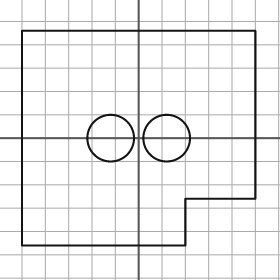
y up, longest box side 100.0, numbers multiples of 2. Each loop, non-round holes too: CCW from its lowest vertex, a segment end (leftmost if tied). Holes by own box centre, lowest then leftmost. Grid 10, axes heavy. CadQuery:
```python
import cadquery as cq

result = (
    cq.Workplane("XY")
    .moveTo(-50.0, -46.0)
    .lineTo(20.0, -46.0)
    .lineTo(20.0, -26.0)
    .lineTo(50.0, -26.0)
    .lineTo(50.0, 46.0)
    .lineTo(-50.0, 46.0)
    .close()
    .moveTo(-12.0, 0.0)
    .circle(10.0)
    .moveTo(12.0, 0.0)
    .circle(10.0)
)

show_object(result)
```